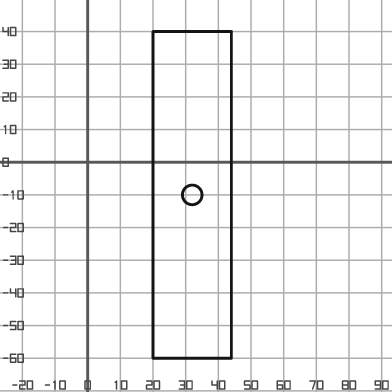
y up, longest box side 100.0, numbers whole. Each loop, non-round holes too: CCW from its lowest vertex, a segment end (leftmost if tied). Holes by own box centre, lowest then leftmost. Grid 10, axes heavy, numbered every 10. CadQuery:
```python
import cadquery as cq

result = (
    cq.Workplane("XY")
    .moveTo(20.0, -60.0)
    .lineTo(44.0, -60.0)
    .lineTo(44.0, 40.0)
    .lineTo(20.0, 40.0)
    .close()
    .moveTo(32.0, -10.0)
    .circle(3.0)
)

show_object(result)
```